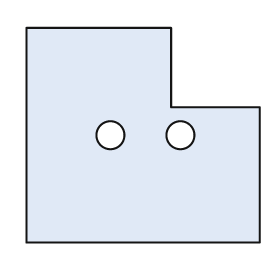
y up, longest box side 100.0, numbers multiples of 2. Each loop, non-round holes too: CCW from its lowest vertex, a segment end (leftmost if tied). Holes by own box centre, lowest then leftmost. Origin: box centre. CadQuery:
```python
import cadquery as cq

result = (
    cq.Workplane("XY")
    .moveTo(-50.0, -46.0)
    .lineTo(50.0, -46.0)
    .lineTo(50.0, 12.0)
    .lineTo(12.0, 12.0)
    .lineTo(12.0, 46.0)
    .lineTo(-50.0, 46.0)
    .close()
    .moveTo(-14.0, 0.0)
    .circle(6.0)
    .moveTo(16.0, 0.0)
    .circle(6.0)
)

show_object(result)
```